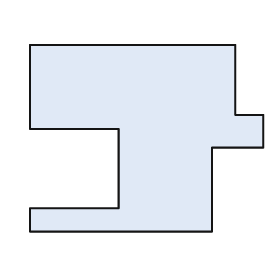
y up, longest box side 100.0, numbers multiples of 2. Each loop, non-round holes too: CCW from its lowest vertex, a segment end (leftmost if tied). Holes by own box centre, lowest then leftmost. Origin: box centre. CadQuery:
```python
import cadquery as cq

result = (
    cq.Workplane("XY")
    .moveTo(-50.0, -40.0)
    .lineTo(28.0, -40.0)
    .lineTo(28.0, -4.0)
    .lineTo(50.0, -4.0)
    .lineTo(50.0, 10.0)
    .lineTo(38.0, 10.0)
    .lineTo(38.0, 40.0)
    .lineTo(-50.0, 40.0)
    .lineTo(-50.0, 4.0)
    .lineTo(-12.0, 4.0)
    .lineTo(-12.0, -30.0)
    .lineTo(-50.0, -30.0)
    .close()
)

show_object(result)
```